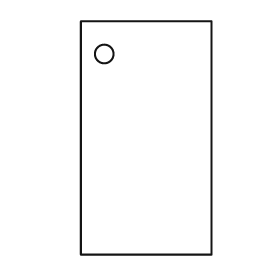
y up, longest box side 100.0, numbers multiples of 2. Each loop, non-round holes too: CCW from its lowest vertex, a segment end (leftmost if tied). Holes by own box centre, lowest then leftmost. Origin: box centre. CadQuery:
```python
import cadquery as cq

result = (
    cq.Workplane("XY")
    .moveTo(-28.0, -50.0)
    .lineTo(28.0, -50.0)
    .lineTo(28.0, 50.0)
    .lineTo(-28.0, 50.0)
    .close()
    .moveTo(-18.0, 36.0)
    .circle(4.0)
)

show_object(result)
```